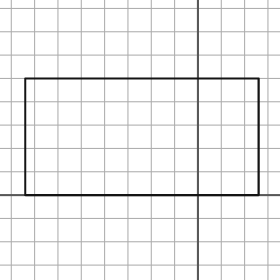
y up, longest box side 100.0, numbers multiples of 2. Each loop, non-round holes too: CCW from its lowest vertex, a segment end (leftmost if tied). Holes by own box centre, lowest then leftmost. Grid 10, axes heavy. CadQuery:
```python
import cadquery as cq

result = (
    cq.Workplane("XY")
    .moveTo(-74.0, 0.0)
    .lineTo(26.0, 0.0)
    .lineTo(26.0, 50.0)
    .lineTo(-74.0, 50.0)
    .close()
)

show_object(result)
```